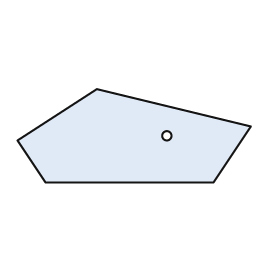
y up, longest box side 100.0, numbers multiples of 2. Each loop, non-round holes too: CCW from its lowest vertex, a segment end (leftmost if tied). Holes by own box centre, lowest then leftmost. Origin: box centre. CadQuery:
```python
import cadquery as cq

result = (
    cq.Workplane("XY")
    .moveTo(-38.0, -20.0)
    .lineTo(34.0, -20.0)
    .lineTo(50.0, 4.0)
    .lineTo(-16.0, 20.0)
    .lineTo(-50.0, -2.0)
    .close()
    .moveTo(14.0, 0.0)
    .circle(2.0)
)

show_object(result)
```